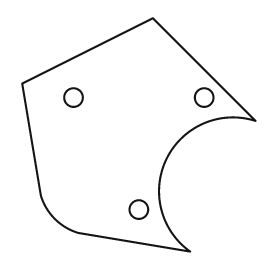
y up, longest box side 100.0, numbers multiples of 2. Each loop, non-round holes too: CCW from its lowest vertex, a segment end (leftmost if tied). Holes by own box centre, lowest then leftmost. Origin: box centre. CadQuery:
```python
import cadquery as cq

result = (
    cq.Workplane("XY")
    .moveTo(22.0, -50.0)
    .threePointArc((12.0, -10.0), (50.0, 6.0))
    .lineTo(6.0, 50.0)
    .lineTo(-50.0, 22.0)
    .lineTo(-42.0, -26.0)
    .threePointArc((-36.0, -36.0), (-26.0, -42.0))
    .close()
    .moveTo(0.0, -32.0)
    .circle(4.0)
    .moveTo(-28.0, 16.0)
    .circle(4.0)
    .moveTo(28.0, 16.0)
    .circle(4.0)
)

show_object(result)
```